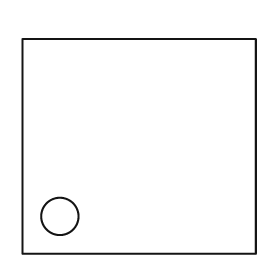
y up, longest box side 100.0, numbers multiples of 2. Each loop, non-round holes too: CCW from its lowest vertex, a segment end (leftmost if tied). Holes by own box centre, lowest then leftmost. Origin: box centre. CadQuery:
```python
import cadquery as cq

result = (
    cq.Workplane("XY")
    .moveTo(-50.0, -46.0)
    .lineTo(50.0, -46.0)
    .lineTo(50.0, 46.0)
    .lineTo(-50.0, 46.0)
    .close()
    .moveTo(-34.0, -30.0)
    .circle(8.0)
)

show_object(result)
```